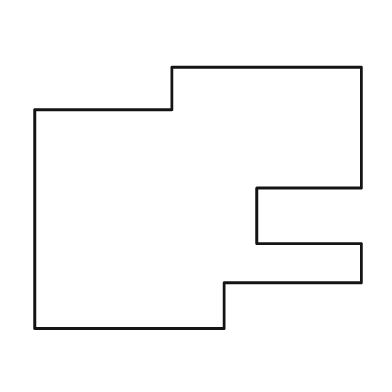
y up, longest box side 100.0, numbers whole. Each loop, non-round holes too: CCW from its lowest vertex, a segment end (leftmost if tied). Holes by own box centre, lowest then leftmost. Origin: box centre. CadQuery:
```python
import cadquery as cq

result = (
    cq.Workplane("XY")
    .moveTo(-50.0, -40.0)
    .lineTo(8.0, -40.0)
    .lineTo(8.0, -26.0)
    .lineTo(50.0, -26.0)
    .lineTo(50.0, -14.0)
    .lineTo(18.0, -14.0)
    .lineTo(18.0, 3.0)
    .lineTo(50.0, 3.0)
    .lineTo(50.0, 40.0)
    .lineTo(-8.0, 40.0)
    .lineTo(-8.0, 27.0)
    .lineTo(-50.0, 27.0)
    .close()
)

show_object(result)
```